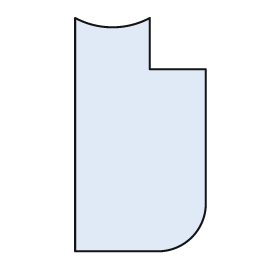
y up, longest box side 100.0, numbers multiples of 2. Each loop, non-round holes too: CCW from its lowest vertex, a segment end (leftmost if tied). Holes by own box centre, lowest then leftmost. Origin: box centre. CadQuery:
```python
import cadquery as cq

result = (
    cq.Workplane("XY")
    .moveTo(-28.0, -50.0)
    .lineTo(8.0, -50.0)
    .threePointArc((22.0, -44.0), (28.0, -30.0))
    .lineTo(28.0, 28.0)
    .lineTo(4.0, 28.0)
    .lineTo(4.0, 50.0)
    .threePointArc((-12.0, 46.0), (-28.0, 50.0))
    .close()
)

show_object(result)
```